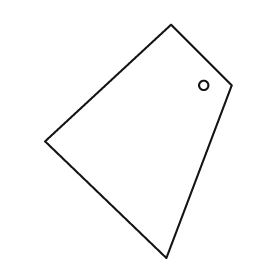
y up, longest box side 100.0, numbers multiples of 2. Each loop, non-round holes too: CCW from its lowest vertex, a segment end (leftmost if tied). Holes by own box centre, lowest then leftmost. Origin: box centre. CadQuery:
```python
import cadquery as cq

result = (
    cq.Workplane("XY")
    .moveTo(12.0, -50.0)
    .lineTo(40.0, 24.0)
    .lineTo(14.0, 50.0)
    .lineTo(-40.0, 0.0)
    .close()
    .moveTo(28.0, 24.0)
    .circle(2.0)
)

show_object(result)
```